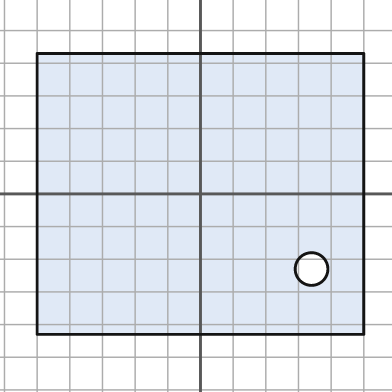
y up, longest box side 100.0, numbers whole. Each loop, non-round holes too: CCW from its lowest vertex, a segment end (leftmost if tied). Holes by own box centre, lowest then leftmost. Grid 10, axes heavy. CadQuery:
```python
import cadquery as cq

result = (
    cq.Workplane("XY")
    .moveTo(-50.0, -43.0)
    .lineTo(50.0, -43.0)
    .lineTo(50.0, 43.0)
    .lineTo(-50.0, 43.0)
    .close()
    .moveTo(34.0, -23.0)
    .circle(5.0)
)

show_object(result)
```